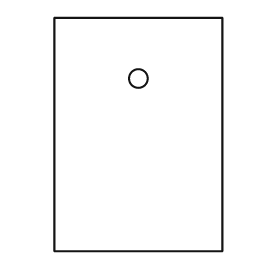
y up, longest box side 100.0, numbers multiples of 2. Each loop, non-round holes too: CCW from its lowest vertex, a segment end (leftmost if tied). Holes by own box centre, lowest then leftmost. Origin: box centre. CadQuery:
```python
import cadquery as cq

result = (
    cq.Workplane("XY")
    .moveTo(-36.0, -50.0)
    .lineTo(36.0, -50.0)
    .lineTo(36.0, 50.0)
    .lineTo(-36.0, 50.0)
    .close()
    .moveTo(0.0, 24.0)
    .circle(4.0)
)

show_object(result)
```